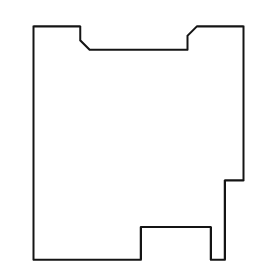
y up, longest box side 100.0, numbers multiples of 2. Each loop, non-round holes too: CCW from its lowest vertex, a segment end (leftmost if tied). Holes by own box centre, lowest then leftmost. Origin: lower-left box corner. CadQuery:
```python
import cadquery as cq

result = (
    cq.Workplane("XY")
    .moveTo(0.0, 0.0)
    .lineTo(46.0, 0.0)
    .lineTo(46.0, 14.0)
    .lineTo(76.0, 14.0)
    .lineTo(76.0, 0.0)
    .lineTo(82.0, 0.0)
    .lineTo(82.0, 34.0)
    .lineTo(90.0, 34.0)
    .lineTo(90.0, 100.0)
    .lineTo(70.0, 100.0)
    .lineTo(66.0, 96.0)
    .lineTo(66.0, 90.0)
    .lineTo(24.0, 90.0)
    .lineTo(20.0, 94.0)
    .lineTo(20.0, 100.0)
    .lineTo(0.0, 100.0)
    .close()
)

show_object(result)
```